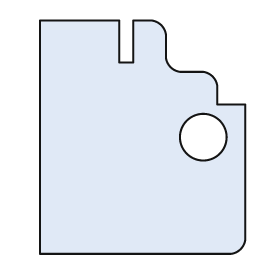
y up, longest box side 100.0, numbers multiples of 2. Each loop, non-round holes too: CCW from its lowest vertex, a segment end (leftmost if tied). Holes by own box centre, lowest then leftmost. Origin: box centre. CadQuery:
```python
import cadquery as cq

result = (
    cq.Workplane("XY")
    .moveTo(-44.0, -50.0)
    .lineTo(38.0, -50.0)
    .threePointArc((42.0, -48.0), (44.0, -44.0))
    .lineTo(44.0, 14.0)
    .lineTo(32.0, 14.0)
    .lineTo(32.0, 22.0)
    .threePointArc((30.0, 26.0), (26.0, 28.0))
    .lineTo(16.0, 28.0)
    .threePointArc((12.0, 30.0), (10.0, 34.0))
    .lineTo(10.0, 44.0)
    .threePointArc((8.0, 48.0), (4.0, 50.0))
    .lineTo(-4.0, 50.0)
    .lineTo(-4.0, 32.0)
    .lineTo(-10.0, 32.0)
    .lineTo(-10.0, 50.0)
    .lineTo(-44.0, 50.0)
    .close()
    .moveTo(26.0, 0.0)
    .circle(10.0)
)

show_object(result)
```